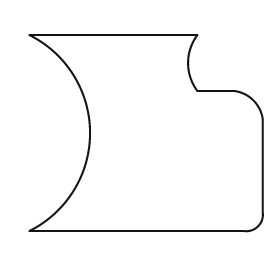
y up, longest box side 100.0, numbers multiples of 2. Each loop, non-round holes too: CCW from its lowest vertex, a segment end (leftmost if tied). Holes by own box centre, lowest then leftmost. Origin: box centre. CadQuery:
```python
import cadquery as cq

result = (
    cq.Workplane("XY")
    .moveTo(-50.0, -42.0)
    .lineTo(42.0, -42.0)
    .threePointArc((48.0, -40.0), (50.0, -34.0))
    .lineTo(50.0, 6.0)
    .threePointArc((46.0, 14.0), (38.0, 18.0))
    .lineTo(22.0, 18.0)
    .threePointArc((18.0, 30.0), (22.0, 42.0))
    .lineTo(-50.0, 42.0)
    .threePointArc((-24.0, 0.0), (-50.0, -42.0))
    .close()
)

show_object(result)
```